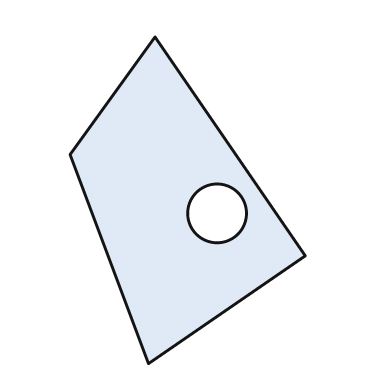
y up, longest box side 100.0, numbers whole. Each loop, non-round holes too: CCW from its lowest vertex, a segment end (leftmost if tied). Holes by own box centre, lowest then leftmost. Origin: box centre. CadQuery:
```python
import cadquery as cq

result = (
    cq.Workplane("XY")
    .moveTo(-12.0, -50.0)
    .lineTo(36.0, -17.0)
    .lineTo(-10.0, 50.0)
    .lineTo(-36.0, 14.0)
    .close()
    .moveTo(9.0, -4.0)
    .circle(9.0)
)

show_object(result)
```